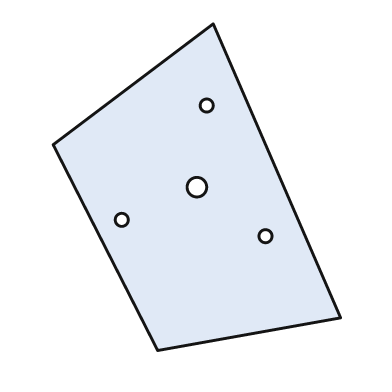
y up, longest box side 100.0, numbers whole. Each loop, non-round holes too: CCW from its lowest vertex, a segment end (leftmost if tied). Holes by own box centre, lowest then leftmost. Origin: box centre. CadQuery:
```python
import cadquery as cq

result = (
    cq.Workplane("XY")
    .moveTo(-12.0, -50.0)
    .lineTo(44.0, -40.0)
    .lineTo(5.0, 50.0)
    .lineTo(-44.0, 13.0)
    .close()
    .moveTo(21.0, -15.0)
    .circle(2.0)
    .moveTo(-23.0, -10.0)
    .circle(2.0)
    .moveTo(0.0, 0.0)
    .circle(3.0)
    .moveTo(3.0, 25.0)
    .circle(2.0)
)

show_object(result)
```